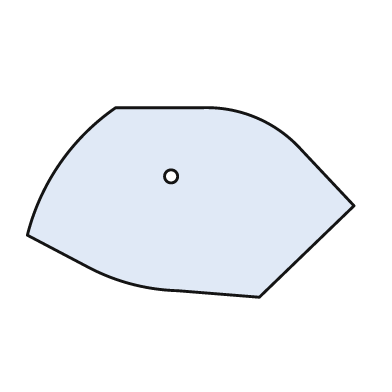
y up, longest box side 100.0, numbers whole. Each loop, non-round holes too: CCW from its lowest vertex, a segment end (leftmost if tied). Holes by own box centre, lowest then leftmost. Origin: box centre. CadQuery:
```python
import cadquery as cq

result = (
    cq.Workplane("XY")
    .moveTo(21.0, -29.0)
    .lineTo(50.0, -1.0)
    .lineTo(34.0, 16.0)
    .threePointArc((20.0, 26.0), (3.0, 29.0))
    .lineTo(-23.0, 29.0)
    .threePointArc((-40.0, 12.0), (-50.0, -10.0))
    .lineTo(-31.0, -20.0)
    .threePointArc((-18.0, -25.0), (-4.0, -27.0))
    .close()
    .moveTo(-6.0, 8.0)
    .circle(2.0)
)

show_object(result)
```